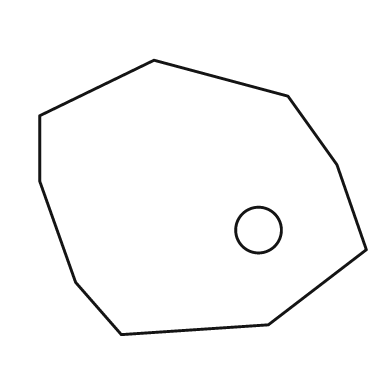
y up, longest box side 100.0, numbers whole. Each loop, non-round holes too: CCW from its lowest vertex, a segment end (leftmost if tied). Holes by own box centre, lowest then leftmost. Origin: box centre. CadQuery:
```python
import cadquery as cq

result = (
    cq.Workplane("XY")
    .moveTo(-25.0, -42.0)
    .lineTo(20.0, -39.0)
    .lineTo(50.0, -16.0)
    .lineTo(41.0, 10.0)
    .lineTo(26.0, 31.0)
    .lineTo(-15.0, 42.0)
    .lineTo(-50.0, 25.0)
    .lineTo(-50.0, 5.0)
    .lineTo(-39.0, -26.0)
    .close()
    .moveTo(17.0, -10.0)
    .circle(7.0)
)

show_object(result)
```